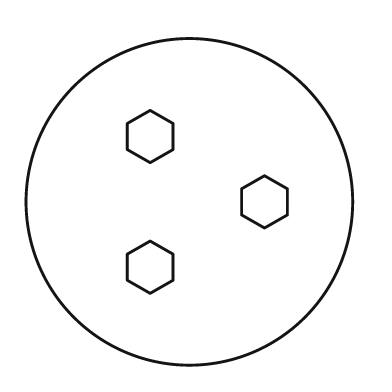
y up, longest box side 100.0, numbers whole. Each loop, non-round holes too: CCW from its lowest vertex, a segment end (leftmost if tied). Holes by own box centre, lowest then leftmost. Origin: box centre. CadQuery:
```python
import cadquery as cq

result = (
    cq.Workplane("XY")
    .moveTo(0.0, 0.0)
    .circle(50.0)
    .moveTo(-12.0, -28.0)
    .lineTo(-5.0, -24.0)
    .lineTo(-5.0, -16.0)
    .lineTo(-12.0, -12.0)
    .lineTo(-19.0, -16.0)
    .lineTo(-19.0, -24.0)
    .close()
    .moveTo(23.0, -8.0)
    .lineTo(30.0, -4.0)
    .lineTo(30.0, 4.0)
    .lineTo(23.0, 8.0)
    .lineTo(16.0, 4.0)
    .lineTo(16.0, -4.0)
    .close()
    .moveTo(-12.0, 12.0)
    .lineTo(-5.0, 16.0)
    .lineTo(-5.0, 24.0)
    .lineTo(-12.0, 28.0)
    .lineTo(-19.0, 24.0)
    .lineTo(-19.0, 16.0)
    .close()
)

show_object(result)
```